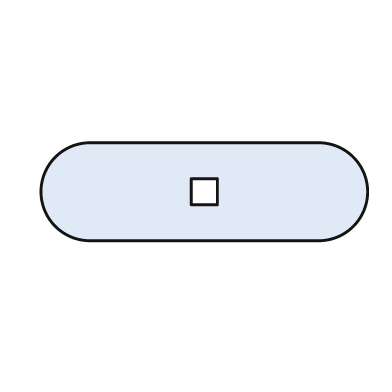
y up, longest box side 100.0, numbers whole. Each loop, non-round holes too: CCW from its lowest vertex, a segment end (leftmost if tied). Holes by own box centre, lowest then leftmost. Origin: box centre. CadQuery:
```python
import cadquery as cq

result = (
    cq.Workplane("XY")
    .moveTo(-35.0, -15.0)
    .lineTo(35.0, -15.0)
    .threePointArc((50.0, 0.0), (35.0, 15.0))
    .lineTo(-35.0, 15.0)
    .threePointArc((-50.0, 0.0), (-35.0, -15.0))
    .close()
    .moveTo(-4.0, -4.0)
    .lineTo(4.0, -4.0)
    .lineTo(4.0, 4.0)
    .lineTo(-4.0, 4.0)
    .close()
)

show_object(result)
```